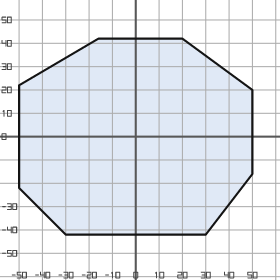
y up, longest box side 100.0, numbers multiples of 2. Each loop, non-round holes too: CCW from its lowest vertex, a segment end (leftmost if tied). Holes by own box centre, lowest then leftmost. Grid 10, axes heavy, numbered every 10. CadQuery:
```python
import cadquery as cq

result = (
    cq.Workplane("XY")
    .moveTo(-30.0, -42.0)
    .lineTo(30.0, -42.0)
    .lineTo(50.0, -16.0)
    .lineTo(50.0, 20.0)
    .lineTo(20.0, 42.0)
    .lineTo(-16.0, 42.0)
    .lineTo(-50.0, 22.0)
    .lineTo(-50.0, -22.0)
    .close()
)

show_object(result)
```